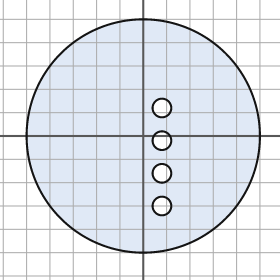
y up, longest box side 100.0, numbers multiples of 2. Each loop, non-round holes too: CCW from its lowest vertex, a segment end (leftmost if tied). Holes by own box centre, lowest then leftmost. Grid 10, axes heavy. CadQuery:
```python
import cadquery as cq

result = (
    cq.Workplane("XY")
    .moveTo(0.0, 0.0)
    .circle(50.0)
    .moveTo(8.0, -30.0)
    .circle(4.0)
    .moveTo(8.0, -16.0)
    .circle(4.0)
    .moveTo(8.0, -2.0)
    .circle(4.0)
    .moveTo(8.0, 12.0)
    .circle(4.0)
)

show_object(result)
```